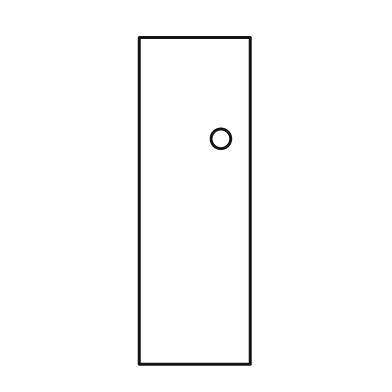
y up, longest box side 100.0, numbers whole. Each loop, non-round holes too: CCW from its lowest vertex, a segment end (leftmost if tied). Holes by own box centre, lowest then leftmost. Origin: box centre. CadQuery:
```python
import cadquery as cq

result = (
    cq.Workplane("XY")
    .moveTo(-17.0, -50.0)
    .lineTo(17.0, -50.0)
    .lineTo(17.0, 50.0)
    .lineTo(-17.0, 50.0)
    .close()
    .moveTo(8.0, 19.0)
    .circle(3.0)
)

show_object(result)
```